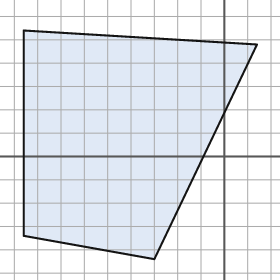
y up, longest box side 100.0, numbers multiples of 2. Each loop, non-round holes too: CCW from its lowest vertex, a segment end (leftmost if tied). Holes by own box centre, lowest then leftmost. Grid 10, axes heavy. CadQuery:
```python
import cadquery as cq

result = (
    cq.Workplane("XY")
    .moveTo(-30.0, -44.0)
    .lineTo(14.0, 48.0)
    .lineTo(-86.0, 54.0)
    .lineTo(-86.0, -34.0)
    .close()
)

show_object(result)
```